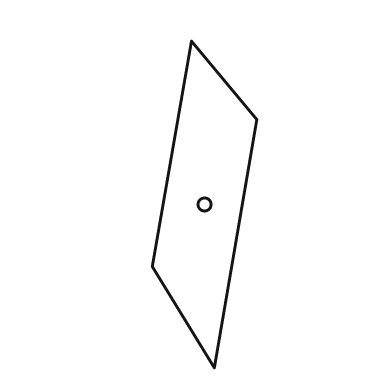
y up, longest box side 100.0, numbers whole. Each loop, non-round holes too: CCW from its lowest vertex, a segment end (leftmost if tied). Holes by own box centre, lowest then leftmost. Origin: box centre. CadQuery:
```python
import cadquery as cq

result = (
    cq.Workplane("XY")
    .moveTo(3.0, -50.0)
    .lineTo(16.0, 26.0)
    .lineTo(-4.0, 50.0)
    .lineTo(-16.0, -19.0)
    .close()
    .moveTo(0.0, 0.0)
    .circle(2.0)
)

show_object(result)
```